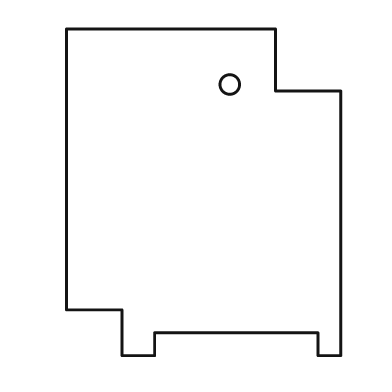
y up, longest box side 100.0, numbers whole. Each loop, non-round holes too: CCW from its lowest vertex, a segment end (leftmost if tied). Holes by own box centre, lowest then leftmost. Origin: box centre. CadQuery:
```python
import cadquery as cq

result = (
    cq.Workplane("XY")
    .moveTo(-25.0, -50.0)
    .lineTo(-15.0, -50.0)
    .lineTo(-15.0, -43.0)
    .lineTo(35.0, -43.0)
    .lineTo(35.0, -50.0)
    .lineTo(42.0, -50.0)
    .lineTo(42.0, 31.0)
    .lineTo(22.0, 31.0)
    .lineTo(22.0, 50.0)
    .lineTo(-42.0, 50.0)
    .lineTo(-42.0, -36.0)
    .lineTo(-25.0, -36.0)
    .close()
    .moveTo(8.0, 33.0)
    .circle(3.0)
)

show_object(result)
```